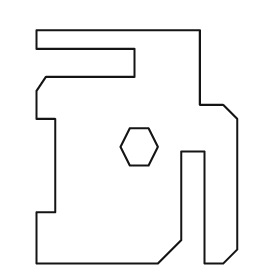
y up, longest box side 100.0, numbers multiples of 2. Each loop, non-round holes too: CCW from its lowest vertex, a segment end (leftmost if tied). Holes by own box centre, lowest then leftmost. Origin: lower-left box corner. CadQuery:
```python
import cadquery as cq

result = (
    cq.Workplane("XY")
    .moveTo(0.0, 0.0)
    .lineTo(52.0, 0.0)
    .lineTo(62.0, 10.0)
    .lineTo(62.0, 48.0)
    .lineTo(72.0, 48.0)
    .lineTo(72.0, 0.0)
    .lineTo(80.0, 0.0)
    .lineTo(86.0, 6.0)
    .lineTo(86.0, 62.0)
    .lineTo(80.0, 68.0)
    .lineTo(70.0, 68.0)
    .lineTo(70.0, 100.0)
    .lineTo(0.0, 100.0)
    .lineTo(0.0, 92.0)
    .lineTo(42.0, 92.0)
    .lineTo(42.0, 80.0)
    .lineTo(4.0, 80.0)
    .lineTo(0.0, 74.0)
    .lineTo(0.0, 62.0)
    .lineTo(8.0, 62.0)
    .lineTo(8.0, 22.0)
    .lineTo(0.0, 22.0)
    .close()
    .moveTo(40.0, 42.0)
    .lineTo(48.0, 42.0)
    .lineTo(52.0, 50.0)
    .lineTo(48.0, 58.0)
    .lineTo(40.0, 58.0)
    .lineTo(36.0, 50.0)
    .close()
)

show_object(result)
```